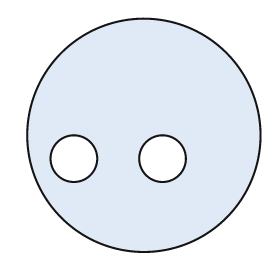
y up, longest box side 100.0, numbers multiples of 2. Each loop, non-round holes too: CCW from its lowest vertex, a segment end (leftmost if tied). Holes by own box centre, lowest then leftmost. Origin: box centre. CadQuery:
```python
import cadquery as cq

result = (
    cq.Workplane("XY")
    .moveTo(0.0, 0.0)
    .circle(50.0)
    .moveTo(-30.0, -10.0)
    .circle(10.0)
    .moveTo(8.0, -10.0)
    .circle(10.0)
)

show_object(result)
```